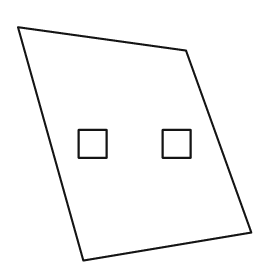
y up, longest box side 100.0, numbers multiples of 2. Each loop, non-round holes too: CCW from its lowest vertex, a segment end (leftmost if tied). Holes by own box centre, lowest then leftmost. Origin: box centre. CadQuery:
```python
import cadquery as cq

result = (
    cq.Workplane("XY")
    .moveTo(-22.0, -50.0)
    .lineTo(50.0, -38.0)
    .lineTo(22.0, 40.0)
    .lineTo(-50.0, 50.0)
    .close()
    .moveTo(-24.0, -6.0)
    .lineTo(-12.0, -6.0)
    .lineTo(-12.0, 6.0)
    .lineTo(-24.0, 6.0)
    .close()
    .moveTo(12.0, -6.0)
    .lineTo(24.0, -6.0)
    .lineTo(24.0, 6.0)
    .lineTo(12.0, 6.0)
    .close()
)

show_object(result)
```